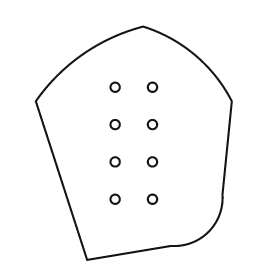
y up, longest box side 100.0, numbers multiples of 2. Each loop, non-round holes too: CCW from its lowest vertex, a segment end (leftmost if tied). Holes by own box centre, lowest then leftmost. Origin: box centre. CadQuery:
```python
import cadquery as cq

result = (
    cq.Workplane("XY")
    .moveTo(-20.0, -50.0)
    .lineTo(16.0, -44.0)
    .threePointArc((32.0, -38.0), (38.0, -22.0))
    .lineTo(42.0, 18.0)
    .threePointArc((26.0, 38.0), (4.0, 50.0))
    .threePointArc((-22.0, 38.0), (-42.0, 18.0))
    .close()
    .moveTo(-8.0, -24.0)
    .circle(2.0)
    .moveTo(8.0, -24.0)
    .circle(2.0)
    .moveTo(-8.0, -8.0)
    .circle(2.0)
    .moveTo(8.0, -8.0)
    .circle(2.0)
    .moveTo(-8.0, 8.0)
    .circle(2.0)
    .moveTo(8.0, 8.0)
    .circle(2.0)
    .moveTo(-8.0, 24.0)
    .circle(2.0)
    .moveTo(8.0, 24.0)
    .circle(2.0)
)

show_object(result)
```